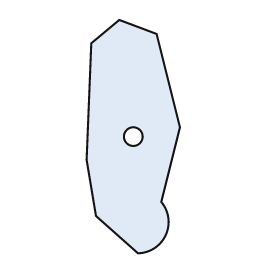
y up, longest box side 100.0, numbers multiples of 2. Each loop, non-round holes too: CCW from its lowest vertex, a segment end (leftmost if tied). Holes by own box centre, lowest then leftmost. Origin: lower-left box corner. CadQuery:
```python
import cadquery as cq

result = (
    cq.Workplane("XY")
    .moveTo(22.0, 0.0)
    .threePointArc((34.0, 8.0), (32.0, 22.0))
    .lineTo(40.0, 54.0)
    .lineTo(30.0, 94.0)
    .lineTo(14.0, 100.0)
    .lineTo(2.0, 90.0)
    .lineTo(0.0, 40.0)
    .lineTo(4.0, 16.0)
    .close()
    .moveTo(20.0, 50.0)
    .circle(4.0)
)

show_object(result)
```